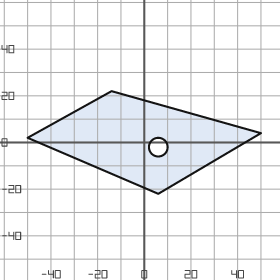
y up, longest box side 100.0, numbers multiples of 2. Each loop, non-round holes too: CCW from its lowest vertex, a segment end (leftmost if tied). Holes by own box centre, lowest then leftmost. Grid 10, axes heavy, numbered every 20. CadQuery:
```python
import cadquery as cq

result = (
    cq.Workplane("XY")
    .moveTo(6.0, -22.0)
    .lineTo(50.0, 4.0)
    .lineTo(-14.0, 22.0)
    .lineTo(-50.0, 2.0)
    .close()
    .moveTo(6.0, -2.0)
    .circle(4.0)
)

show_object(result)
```